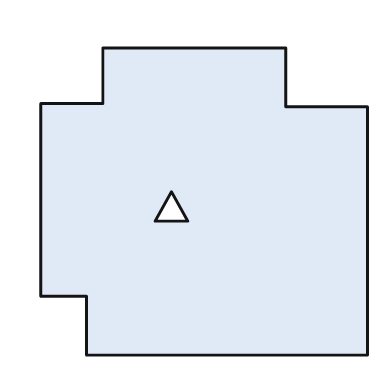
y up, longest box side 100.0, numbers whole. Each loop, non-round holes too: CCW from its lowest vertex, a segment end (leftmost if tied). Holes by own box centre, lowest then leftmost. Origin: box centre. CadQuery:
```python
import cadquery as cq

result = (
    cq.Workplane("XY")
    .moveTo(-36.0, -47.0)
    .lineTo(50.0, -47.0)
    .lineTo(50.0, 29.0)
    .lineTo(25.0, 29.0)
    .lineTo(25.0, 47.0)
    .lineTo(-31.0, 47.0)
    .lineTo(-31.0, 30.0)
    .lineTo(-50.0, 30.0)
    .lineTo(-50.0, -29.0)
    .lineTo(-36.0, -29.0)
    .close()
    .moveTo(-15.0, -6.0)
    .lineTo(-5.0, -6.0)
    .lineTo(-10.0, 3.0)
    .close()
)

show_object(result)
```